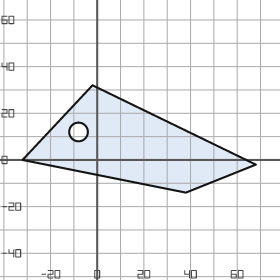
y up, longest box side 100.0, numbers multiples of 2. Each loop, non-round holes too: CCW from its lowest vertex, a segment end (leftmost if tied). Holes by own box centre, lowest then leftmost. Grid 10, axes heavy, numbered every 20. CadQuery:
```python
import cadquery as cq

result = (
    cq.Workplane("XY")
    .moveTo(38.0, -14.0)
    .lineTo(68.0, -2.0)
    .lineTo(-2.0, 32.0)
    .lineTo(-32.0, 0.0)
    .close()
    .moveTo(-8.0, 12.0)
    .circle(4.0)
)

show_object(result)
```